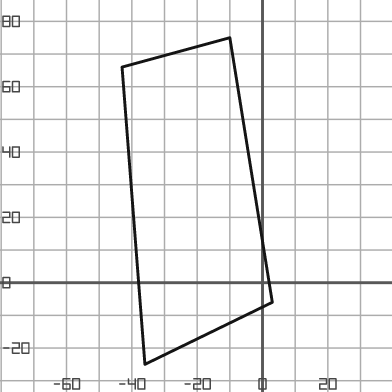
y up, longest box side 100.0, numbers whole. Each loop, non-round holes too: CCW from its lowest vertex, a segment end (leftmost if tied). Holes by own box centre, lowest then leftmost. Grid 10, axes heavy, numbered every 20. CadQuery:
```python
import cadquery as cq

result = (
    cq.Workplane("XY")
    .moveTo(-36.0, -25.0)
    .lineTo(3.0, -6.0)
    .lineTo(-10.0, 75.0)
    .lineTo(-43.0, 66.0)
    .close()
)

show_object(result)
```